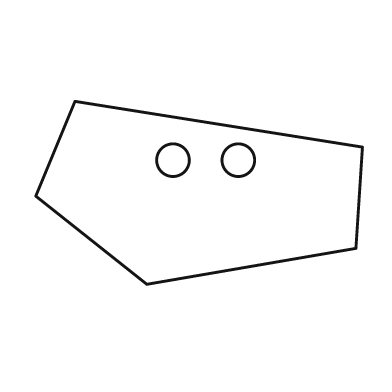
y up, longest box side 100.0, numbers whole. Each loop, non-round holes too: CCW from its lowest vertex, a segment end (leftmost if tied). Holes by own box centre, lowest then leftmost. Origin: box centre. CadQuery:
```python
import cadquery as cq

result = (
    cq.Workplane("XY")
    .moveTo(-16.0, -28.0)
    .lineTo(48.0, -17.0)
    .lineTo(50.0, 14.0)
    .lineTo(-38.0, 28.0)
    .lineTo(-50.0, -1.0)
    .close()
    .moveTo(-8.0, 10.0)
    .circle(5.0)
    .moveTo(12.0, 10.0)
    .circle(5.0)
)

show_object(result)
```